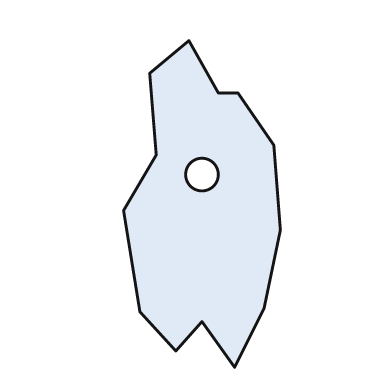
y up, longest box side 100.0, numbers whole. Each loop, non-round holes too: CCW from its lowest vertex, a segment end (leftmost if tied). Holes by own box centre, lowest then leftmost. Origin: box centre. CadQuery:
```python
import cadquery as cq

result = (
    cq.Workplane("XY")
    .moveTo(10.0, -50.0)
    .lineTo(19.0, -32.0)
    .lineTo(24.0, -8.0)
    .lineTo(22.0, 18.0)
    .lineTo(11.0, 34.0)
    .lineTo(5.0, 34.0)
    .lineTo(-4.0, 50.0)
    .lineTo(-16.0, 40.0)
    .lineTo(-14.0, 15.0)
    .lineTo(-24.0, -2.0)
    .lineTo(-19.0, -33.0)
    .lineTo(-8.0, -45.0)
    .lineTo(0.0, -36.0)
    .close()
    .moveTo(0.0, 9.0)
    .circle(5.0)
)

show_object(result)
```